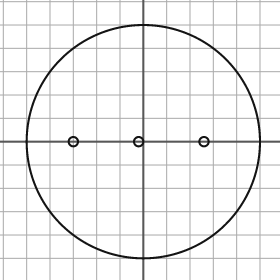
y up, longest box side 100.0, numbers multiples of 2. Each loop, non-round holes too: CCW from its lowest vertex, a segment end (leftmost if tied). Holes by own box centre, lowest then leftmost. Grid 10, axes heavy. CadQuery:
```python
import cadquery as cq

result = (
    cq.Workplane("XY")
    .moveTo(0.0, 0.0)
    .circle(50.0)
    .moveTo(-30.0, 0.0)
    .circle(2.0)
    .moveTo(-2.0, 0.0)
    .circle(2.0)
    .moveTo(26.0, 0.0)
    .circle(2.0)
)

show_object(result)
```